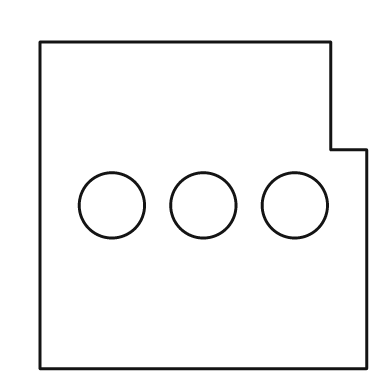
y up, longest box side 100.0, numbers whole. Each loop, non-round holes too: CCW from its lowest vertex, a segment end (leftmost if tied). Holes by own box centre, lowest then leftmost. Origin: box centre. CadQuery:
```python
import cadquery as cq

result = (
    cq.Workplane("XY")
    .moveTo(-50.0, -50.0)
    .lineTo(50.0, -50.0)
    .lineTo(50.0, 17.0)
    .lineTo(39.0, 17.0)
    .lineTo(39.0, 50.0)
    .lineTo(-50.0, 50.0)
    .close()
    .moveTo(-28.0, 0.0)
    .circle(10.0)
    .moveTo(0.0, 0.0)
    .circle(10.0)
    .moveTo(28.0, 0.0)
    .circle(10.0)
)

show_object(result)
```